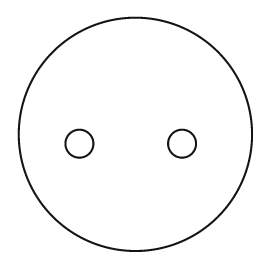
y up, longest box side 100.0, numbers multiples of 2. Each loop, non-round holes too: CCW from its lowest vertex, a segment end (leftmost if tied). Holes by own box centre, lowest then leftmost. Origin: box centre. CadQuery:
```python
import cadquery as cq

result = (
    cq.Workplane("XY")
    .moveTo(0.0, 0.0)
    .circle(50.0)
    .moveTo(-24.0, -4.0)
    .circle(6.0)
    .moveTo(20.0, -4.0)
    .circle(6.0)
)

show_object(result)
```